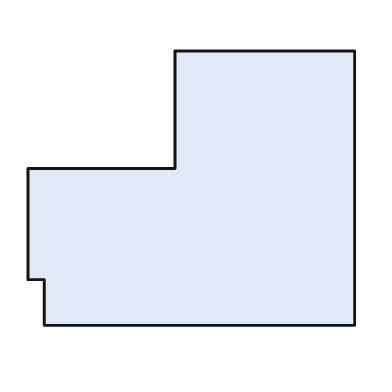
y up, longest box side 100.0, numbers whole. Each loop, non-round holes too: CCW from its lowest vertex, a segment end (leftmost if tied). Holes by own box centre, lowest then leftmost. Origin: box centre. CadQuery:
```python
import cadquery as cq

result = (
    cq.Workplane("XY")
    .moveTo(-45.0, -42.0)
    .lineTo(50.0, -42.0)
    .lineTo(50.0, 42.0)
    .lineTo(-5.0, 42.0)
    .lineTo(-5.0, 6.0)
    .lineTo(-50.0, 6.0)
    .lineTo(-50.0, -28.0)
    .lineTo(-45.0, -28.0)
    .close()
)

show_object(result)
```